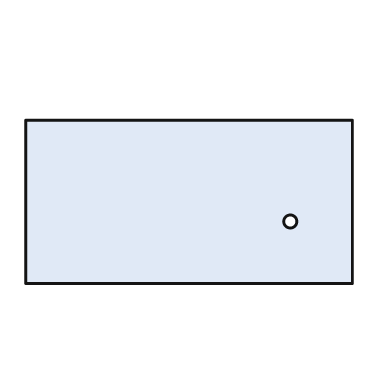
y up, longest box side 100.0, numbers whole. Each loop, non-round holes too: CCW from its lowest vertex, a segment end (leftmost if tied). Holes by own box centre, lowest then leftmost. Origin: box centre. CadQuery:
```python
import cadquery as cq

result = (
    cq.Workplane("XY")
    .moveTo(-50.0, -25.0)
    .lineTo(50.0, -25.0)
    .lineTo(50.0, 25.0)
    .lineTo(-50.0, 25.0)
    .close()
    .moveTo(31.0, -6.0)
    .circle(2.0)
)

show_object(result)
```